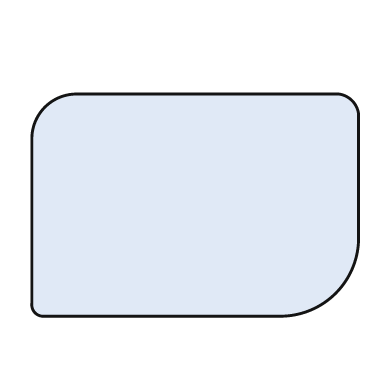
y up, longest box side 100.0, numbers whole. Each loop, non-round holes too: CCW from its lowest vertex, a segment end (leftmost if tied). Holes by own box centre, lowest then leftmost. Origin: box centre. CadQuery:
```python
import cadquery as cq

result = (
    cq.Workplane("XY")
    .moveTo(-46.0, -34.0)
    .lineTo(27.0, -34.0)
    .threePointArc((43.0, -27.0), (50.0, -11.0))
    .lineTo(50.0, 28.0)
    .threePointArc((48.0, 32.0), (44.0, 34.0))
    .lineTo(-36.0, 34.0)
    .threePointArc((-46.0, 30.0), (-50.0, 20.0))
    .lineTo(-50.0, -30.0)
    .threePointArc((-49.0, -33.0), (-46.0, -34.0))
    .close()
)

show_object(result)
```